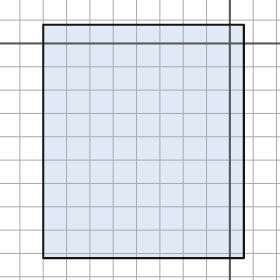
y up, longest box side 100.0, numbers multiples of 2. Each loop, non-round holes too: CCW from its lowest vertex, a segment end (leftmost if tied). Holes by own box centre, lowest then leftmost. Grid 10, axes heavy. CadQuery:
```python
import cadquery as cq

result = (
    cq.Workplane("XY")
    .moveTo(-80.0, -92.0)
    .lineTo(6.0, -92.0)
    .lineTo(6.0, 8.0)
    .lineTo(-80.0, 8.0)
    .close()
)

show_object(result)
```